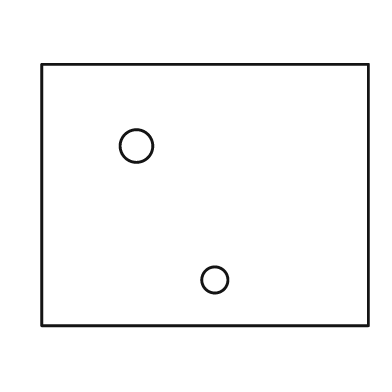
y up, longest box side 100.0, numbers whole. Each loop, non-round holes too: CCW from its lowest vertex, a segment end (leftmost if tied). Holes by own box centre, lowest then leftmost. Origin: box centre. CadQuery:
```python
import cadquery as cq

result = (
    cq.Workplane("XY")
    .moveTo(-50.0, -40.0)
    .lineTo(50.0, -40.0)
    .lineTo(50.0, 40.0)
    .lineTo(-50.0, 40.0)
    .close()
    .moveTo(3.0, -26.0)
    .circle(4.0)
    .moveTo(-21.0, 15.0)
    .circle(5.0)
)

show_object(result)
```